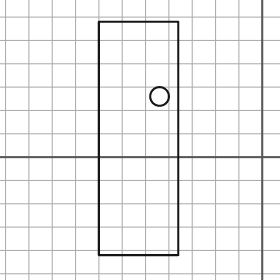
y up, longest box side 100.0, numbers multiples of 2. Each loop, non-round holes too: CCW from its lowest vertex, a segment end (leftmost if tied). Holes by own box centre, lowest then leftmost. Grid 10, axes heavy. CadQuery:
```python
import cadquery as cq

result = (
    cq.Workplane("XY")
    .moveTo(-70.0, -42.0)
    .lineTo(-36.0, -42.0)
    .lineTo(-36.0, 58.0)
    .lineTo(-70.0, 58.0)
    .close()
    .moveTo(-44.0, 26.0)
    .circle(4.0)
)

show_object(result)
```